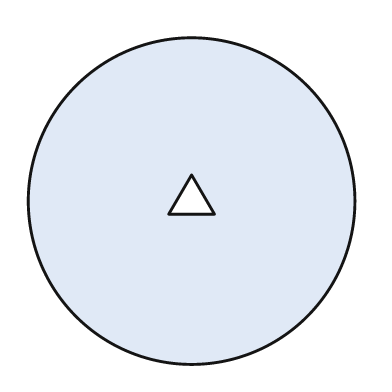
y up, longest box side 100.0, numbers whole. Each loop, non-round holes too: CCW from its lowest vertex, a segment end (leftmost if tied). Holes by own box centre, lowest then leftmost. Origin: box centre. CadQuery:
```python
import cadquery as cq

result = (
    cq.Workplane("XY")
    .moveTo(0.0, 0.0)
    .circle(50.0)
    .moveTo(-7.0, -4.0)
    .lineTo(7.0, -4.0)
    .lineTo(0.0, 8.0)
    .close()
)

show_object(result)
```